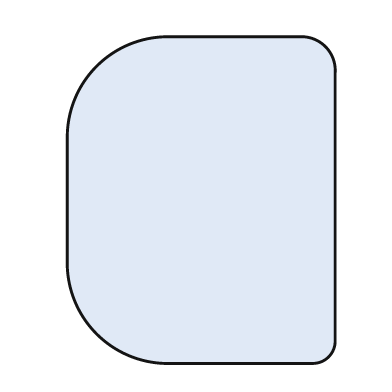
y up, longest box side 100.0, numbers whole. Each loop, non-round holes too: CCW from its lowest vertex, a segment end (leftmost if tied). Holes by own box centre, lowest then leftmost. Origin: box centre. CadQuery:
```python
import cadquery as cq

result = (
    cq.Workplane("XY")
    .moveTo(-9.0, -50.0)
    .lineTo(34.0, -50.0)
    .threePointArc((39.0, -48.0), (41.0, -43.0))
    .lineTo(41.0, 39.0)
    .threePointArc((38.0, 47.0), (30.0, 50.0))
    .lineTo(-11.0, 50.0)
    .threePointArc((-32.0, 41.0), (-41.0, 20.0))
    .lineTo(-41.0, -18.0)
    .threePointArc((-32.0, -41.0), (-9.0, -50.0))
    .close()
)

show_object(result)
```